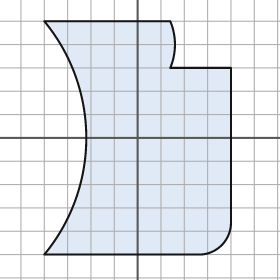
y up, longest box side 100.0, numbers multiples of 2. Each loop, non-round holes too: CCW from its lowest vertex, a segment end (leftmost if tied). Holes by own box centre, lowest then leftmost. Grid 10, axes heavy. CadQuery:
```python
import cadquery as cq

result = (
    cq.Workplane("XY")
    .moveTo(-40.0, -50.0)
    .lineTo(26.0, -50.0)
    .threePointArc((36.0, -46.0), (40.0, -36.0))
    .lineTo(40.0, 30.0)
    .lineTo(14.0, 30.0)
    .threePointArc((16.0, 40.0), (14.0, 50.0))
    .lineTo(-40.0, 50.0)
    .threePointArc((-22.0, 0.0), (-40.0, -50.0))
    .close()
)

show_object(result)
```